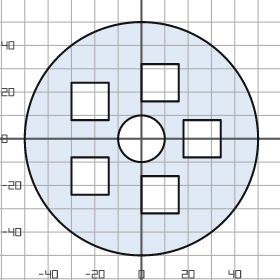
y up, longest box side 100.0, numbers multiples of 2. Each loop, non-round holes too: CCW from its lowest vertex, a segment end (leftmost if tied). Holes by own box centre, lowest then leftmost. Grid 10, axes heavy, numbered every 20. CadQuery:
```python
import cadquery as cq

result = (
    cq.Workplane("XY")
    .moveTo(0.0, 0.0)
    .circle(50.0)
    .moveTo(0.0, -32.0)
    .lineTo(16.0, -32.0)
    .lineTo(16.0, -16.0)
    .lineTo(0.0, -16.0)
    .close()
    .moveTo(-30.0, -24.0)
    .lineTo(-14.0, -24.0)
    .lineTo(-14.0, -8.0)
    .lineTo(-30.0, -8.0)
    .close()
    .moveTo(0.0, 0.0)
    .circle(10.0)
    .moveTo(18.0, -8.0)
    .lineTo(34.0, -8.0)
    .lineTo(34.0, 8.0)
    .lineTo(18.0, 8.0)
    .close()
    .moveTo(-30.0, 8.0)
    .lineTo(-14.0, 8.0)
    .lineTo(-14.0, 24.0)
    .lineTo(-30.0, 24.0)
    .close()
    .moveTo(0.0, 16.0)
    .lineTo(16.0, 16.0)
    .lineTo(16.0, 32.0)
    .lineTo(0.0, 32.0)
    .close()
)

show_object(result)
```